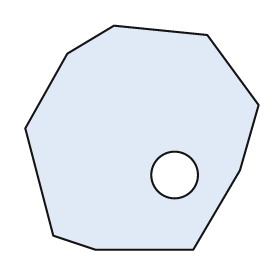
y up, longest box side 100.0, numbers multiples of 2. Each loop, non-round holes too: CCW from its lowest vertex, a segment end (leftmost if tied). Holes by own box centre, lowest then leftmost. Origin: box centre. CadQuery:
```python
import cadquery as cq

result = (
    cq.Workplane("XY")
    .moveTo(-20.0, -48.0)
    .lineTo(22.0, -48.0)
    .lineTo(42.0, -14.0)
    .lineTo(50.0, 14.0)
    .lineTo(28.0, 44.0)
    .lineTo(-12.0, 48.0)
    .lineTo(-32.0, 36.0)
    .lineTo(-50.0, 4.0)
    .lineTo(-38.0, -42.0)
    .close()
    .moveTo(14.0, -16.0)
    .circle(10.0)
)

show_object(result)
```